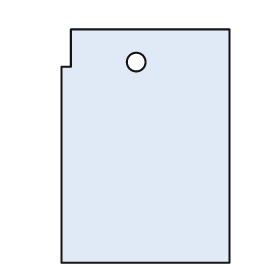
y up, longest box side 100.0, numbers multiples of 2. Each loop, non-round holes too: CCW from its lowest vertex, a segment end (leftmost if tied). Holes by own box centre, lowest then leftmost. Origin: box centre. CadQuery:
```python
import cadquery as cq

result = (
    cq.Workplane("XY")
    .moveTo(-36.0, -50.0)
    .lineTo(36.0, -50.0)
    .lineTo(36.0, 50.0)
    .lineTo(-32.0, 50.0)
    .lineTo(-32.0, 34.0)
    .lineTo(-36.0, 34.0)
    .close()
    .moveTo(-4.0, 36.0)
    .circle(4.0)
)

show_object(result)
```